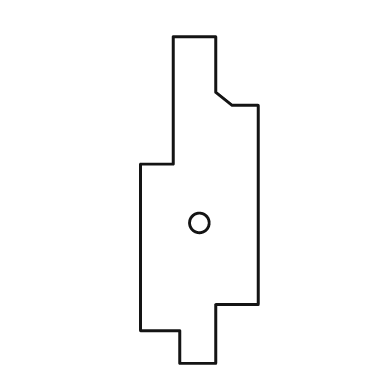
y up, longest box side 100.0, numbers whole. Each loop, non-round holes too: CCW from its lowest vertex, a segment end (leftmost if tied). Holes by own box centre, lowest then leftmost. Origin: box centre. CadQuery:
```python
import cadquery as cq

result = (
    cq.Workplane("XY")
    .moveTo(-6.0, -50.0)
    .lineTo(5.0, -50.0)
    .lineTo(5.0, -32.0)
    .lineTo(18.0, -32.0)
    .lineTo(18.0, 29.0)
    .lineTo(10.0, 29.0)
    .lineTo(5.0, 33.0)
    .lineTo(5.0, 50.0)
    .lineTo(-8.0, 50.0)
    .lineTo(-8.0, 11.0)
    .lineTo(-18.0, 11.0)
    .lineTo(-18.0, -40.0)
    .lineTo(-6.0, -40.0)
    .close()
    .moveTo(0.0, -7.0)
    .circle(3.0)
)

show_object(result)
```